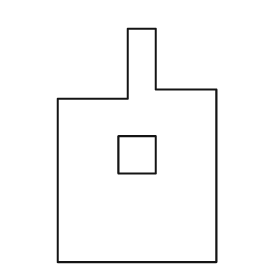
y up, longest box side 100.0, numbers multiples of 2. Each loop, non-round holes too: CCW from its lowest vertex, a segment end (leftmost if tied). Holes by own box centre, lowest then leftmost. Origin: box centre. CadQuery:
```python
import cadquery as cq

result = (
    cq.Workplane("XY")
    .moveTo(-34.0, -50.0)
    .lineTo(34.0, -50.0)
    .lineTo(34.0, 24.0)
    .lineTo(8.0, 24.0)
    .lineTo(8.0, 50.0)
    .lineTo(-4.0, 50.0)
    .lineTo(-4.0, 20.0)
    .lineTo(-34.0, 20.0)
    .close()
    .moveTo(-8.0, -12.0)
    .lineTo(8.0, -12.0)
    .lineTo(8.0, 4.0)
    .lineTo(-8.0, 4.0)
    .close()
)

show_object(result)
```